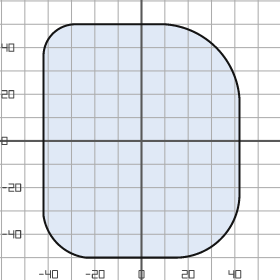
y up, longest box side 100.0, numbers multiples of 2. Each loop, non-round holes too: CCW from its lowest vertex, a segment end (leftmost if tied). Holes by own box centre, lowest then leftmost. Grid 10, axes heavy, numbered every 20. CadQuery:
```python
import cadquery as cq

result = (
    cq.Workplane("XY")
    .moveTo(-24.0, -50.0)
    .lineTo(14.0, -50.0)
    .threePointArc((34.0, -42.0), (42.0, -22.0))
    .lineTo(42.0, 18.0)
    .threePointArc((32.0, 40.0), (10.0, 50.0))
    .lineTo(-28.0, 50.0)
    .threePointArc((-38.0, 46.0), (-42.0, 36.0))
    .lineTo(-42.0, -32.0)
    .threePointArc((-36.0, -44.0), (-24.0, -50.0))
    .close()
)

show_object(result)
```